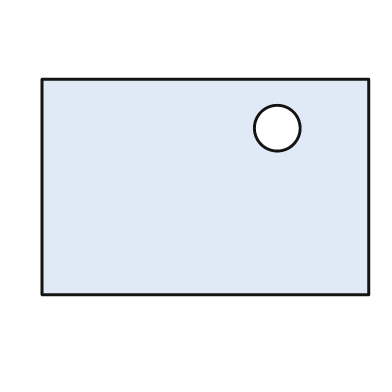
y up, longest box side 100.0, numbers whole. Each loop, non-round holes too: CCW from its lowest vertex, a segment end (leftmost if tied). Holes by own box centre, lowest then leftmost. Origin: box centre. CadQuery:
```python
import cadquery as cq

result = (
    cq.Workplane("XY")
    .moveTo(-50.0, -33.0)
    .lineTo(50.0, -33.0)
    .lineTo(50.0, 33.0)
    .lineTo(-50.0, 33.0)
    .close()
    .moveTo(22.0, 18.0)
    .circle(7.0)
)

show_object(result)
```